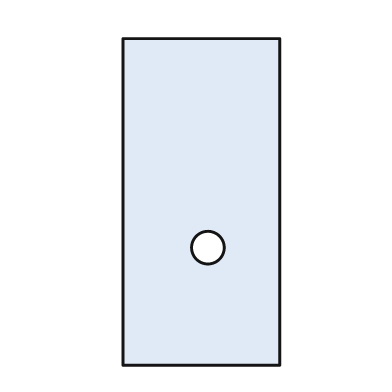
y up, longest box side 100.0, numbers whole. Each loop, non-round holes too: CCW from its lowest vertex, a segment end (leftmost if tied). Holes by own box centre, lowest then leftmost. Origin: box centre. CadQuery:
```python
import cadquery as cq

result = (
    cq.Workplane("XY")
    .moveTo(-24.0, -50.0)
    .lineTo(24.0, -50.0)
    .lineTo(24.0, 50.0)
    .lineTo(-24.0, 50.0)
    .close()
    .moveTo(2.0, -14.0)
    .circle(5.0)
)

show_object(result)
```